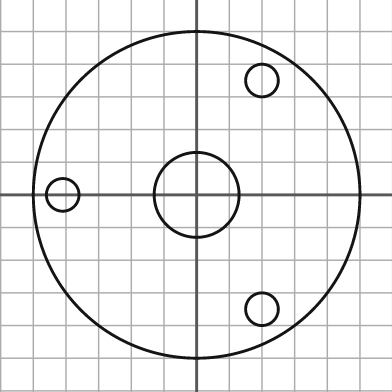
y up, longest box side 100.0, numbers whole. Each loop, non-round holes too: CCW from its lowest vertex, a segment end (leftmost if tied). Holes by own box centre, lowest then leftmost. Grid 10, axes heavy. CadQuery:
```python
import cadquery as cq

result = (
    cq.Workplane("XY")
    .moveTo(0.0, 0.0)
    .circle(50.0)
    .moveTo(20.0, -35.0)
    .circle(5.0)
    .moveTo(-41.0, 0.0)
    .circle(5.0)
    .moveTo(0.0, 0.0)
    .circle(13.0)
    .moveTo(20.0, 35.0)
    .circle(5.0)
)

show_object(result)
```